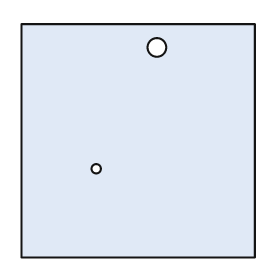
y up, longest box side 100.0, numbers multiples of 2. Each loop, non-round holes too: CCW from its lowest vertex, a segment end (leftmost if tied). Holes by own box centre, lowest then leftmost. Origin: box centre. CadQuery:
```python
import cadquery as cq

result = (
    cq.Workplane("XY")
    .moveTo(-50.0, -50.0)
    .lineTo(50.0, -50.0)
    .lineTo(50.0, 50.0)
    .lineTo(-50.0, 50.0)
    .close()
    .moveTo(-18.0, -12.0)
    .circle(2.0)
    .moveTo(8.0, 40.0)
    .circle(4.0)
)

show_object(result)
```